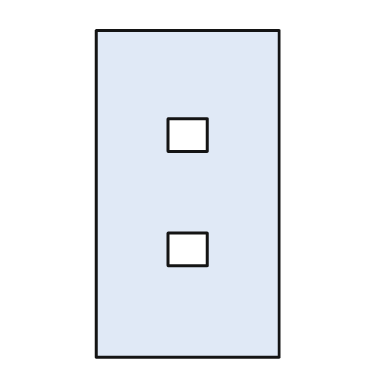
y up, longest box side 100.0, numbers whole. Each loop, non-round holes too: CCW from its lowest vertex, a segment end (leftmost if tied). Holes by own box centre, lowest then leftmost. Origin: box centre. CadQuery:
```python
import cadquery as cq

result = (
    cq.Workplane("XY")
    .moveTo(-28.0, -50.0)
    .lineTo(28.0, -50.0)
    .lineTo(28.0, 50.0)
    .lineTo(-28.0, 50.0)
    .close()
    .moveTo(-6.0, -22.0)
    .lineTo(6.0, -22.0)
    .lineTo(6.0, -12.0)
    .lineTo(-6.0, -12.0)
    .close()
    .moveTo(-6.0, 13.0)
    .lineTo(6.0, 13.0)
    .lineTo(6.0, 23.0)
    .lineTo(-6.0, 23.0)
    .close()
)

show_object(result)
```